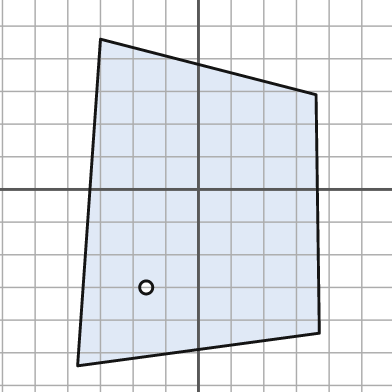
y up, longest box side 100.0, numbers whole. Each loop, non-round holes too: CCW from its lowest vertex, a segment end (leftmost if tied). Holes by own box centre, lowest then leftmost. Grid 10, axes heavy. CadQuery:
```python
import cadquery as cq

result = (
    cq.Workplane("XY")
    .moveTo(-37.0, -54.0)
    .lineTo(37.0, -44.0)
    .lineTo(36.0, 29.0)
    .lineTo(-30.0, 46.0)
    .close()
    .moveTo(-16.0, -30.0)
    .circle(2.0)
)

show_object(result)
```